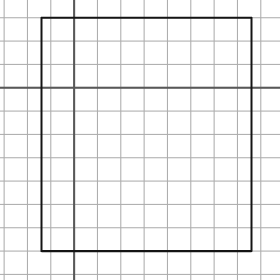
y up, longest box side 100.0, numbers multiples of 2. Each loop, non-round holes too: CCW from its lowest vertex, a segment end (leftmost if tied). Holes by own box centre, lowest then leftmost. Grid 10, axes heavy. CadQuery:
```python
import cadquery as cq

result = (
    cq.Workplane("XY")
    .moveTo(-14.0, -70.0)
    .lineTo(76.0, -70.0)
    .lineTo(76.0, 30.0)
    .lineTo(-14.0, 30.0)
    .close()
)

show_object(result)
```